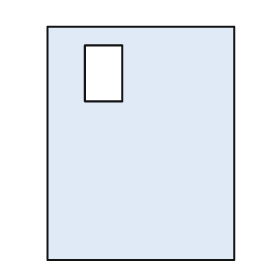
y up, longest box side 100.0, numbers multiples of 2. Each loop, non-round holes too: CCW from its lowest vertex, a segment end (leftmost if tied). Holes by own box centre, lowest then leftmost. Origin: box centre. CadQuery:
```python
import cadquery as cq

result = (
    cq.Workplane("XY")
    .moveTo(-40.0, -50.0)
    .lineTo(40.0, -50.0)
    .lineTo(40.0, 50.0)
    .lineTo(-40.0, 50.0)
    .close()
    .moveTo(-24.0, 18.0)
    .lineTo(-8.0, 18.0)
    .lineTo(-8.0, 42.0)
    .lineTo(-24.0, 42.0)
    .close()
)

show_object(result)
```